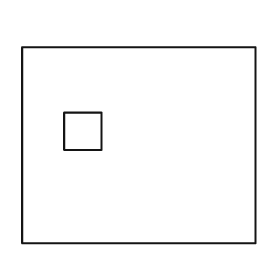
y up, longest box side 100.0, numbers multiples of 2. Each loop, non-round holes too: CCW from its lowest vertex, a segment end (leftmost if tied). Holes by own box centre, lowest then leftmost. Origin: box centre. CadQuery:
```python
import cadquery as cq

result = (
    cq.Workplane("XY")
    .moveTo(-50.0, -42.0)
    .lineTo(50.0, -42.0)
    .lineTo(50.0, 42.0)
    .lineTo(-50.0, 42.0)
    .close()
    .moveTo(-32.0, -2.0)
    .lineTo(-16.0, -2.0)
    .lineTo(-16.0, 14.0)
    .lineTo(-32.0, 14.0)
    .close()
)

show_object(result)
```